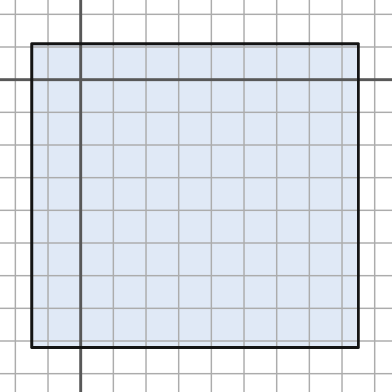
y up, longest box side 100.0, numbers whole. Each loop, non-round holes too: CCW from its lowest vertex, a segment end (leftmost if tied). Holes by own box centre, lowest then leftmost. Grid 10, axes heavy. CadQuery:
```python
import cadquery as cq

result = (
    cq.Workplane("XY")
    .moveTo(-15.0, -82.0)
    .lineTo(85.0, -82.0)
    .lineTo(85.0, 11.0)
    .lineTo(-15.0, 11.0)
    .close()
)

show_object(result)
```